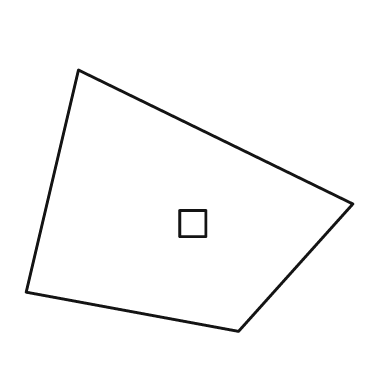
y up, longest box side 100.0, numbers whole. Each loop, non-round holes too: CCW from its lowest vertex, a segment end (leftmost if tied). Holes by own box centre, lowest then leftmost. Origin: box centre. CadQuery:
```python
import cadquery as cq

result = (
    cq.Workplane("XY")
    .moveTo(15.0, -40.0)
    .lineTo(50.0, -1.0)
    .lineTo(-34.0, 40.0)
    .lineTo(-50.0, -28.0)
    .close()
    .moveTo(-3.0, -11.0)
    .lineTo(5.0, -11.0)
    .lineTo(5.0, -3.0)
    .lineTo(-3.0, -3.0)
    .close()
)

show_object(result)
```